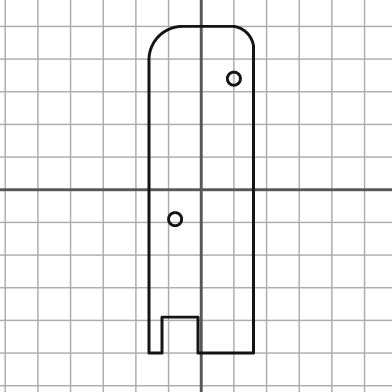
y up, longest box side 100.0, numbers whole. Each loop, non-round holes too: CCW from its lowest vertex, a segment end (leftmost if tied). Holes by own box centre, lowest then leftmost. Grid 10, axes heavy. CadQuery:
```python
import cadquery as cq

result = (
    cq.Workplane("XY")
    .moveTo(-16.0, -50.0)
    .lineTo(-12.0, -50.0)
    .lineTo(-12.0, -39.0)
    .lineTo(-1.0, -39.0)
    .lineTo(-1.0, -50.0)
    .lineTo(16.0, -50.0)
    .lineTo(16.0, 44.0)
    .threePointArc((14.0, 48.0), (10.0, 50.0))
    .lineTo(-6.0, 50.0)
    .threePointArc((-13.0, 47.0), (-16.0, 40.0))
    .close()
    .moveTo(-8.0, -9.0)
    .circle(2.0)
    .moveTo(10.0, 34.0)
    .circle(2.0)
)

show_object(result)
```